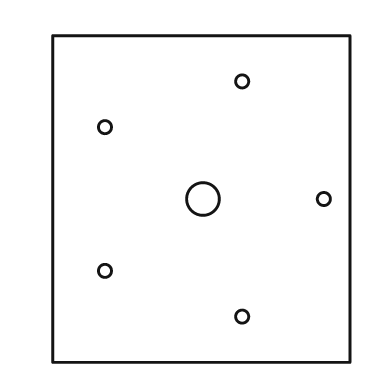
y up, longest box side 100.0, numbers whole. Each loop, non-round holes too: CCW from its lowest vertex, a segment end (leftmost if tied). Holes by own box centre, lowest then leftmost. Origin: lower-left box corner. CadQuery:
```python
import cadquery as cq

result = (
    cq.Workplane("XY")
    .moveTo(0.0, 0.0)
    .lineTo(91.0, 0.0)
    .lineTo(91.0, 100.0)
    .lineTo(0.0, 100.0)
    .close()
    .moveTo(58.0, 14.0)
    .circle(2.0)
    .moveTo(16.0, 28.0)
    .circle(2.0)
    .moveTo(46.0, 50.0)
    .circle(5.0)
    .moveTo(83.0, 50.0)
    .circle(2.0)
    .moveTo(16.0, 72.0)
    .circle(2.0)
    .moveTo(58.0, 86.0)
    .circle(2.0)
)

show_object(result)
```